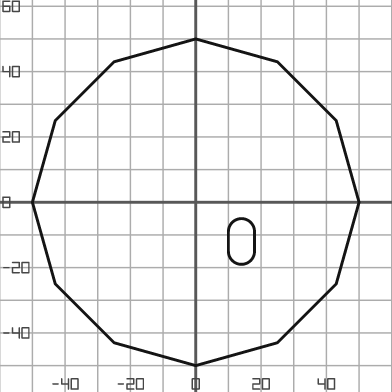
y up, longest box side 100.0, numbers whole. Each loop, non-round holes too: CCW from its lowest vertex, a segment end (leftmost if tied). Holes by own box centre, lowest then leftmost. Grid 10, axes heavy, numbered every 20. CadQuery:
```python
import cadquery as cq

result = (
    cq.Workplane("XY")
    .moveTo(0.0, -50.0)
    .lineTo(25.0, -43.0)
    .lineTo(43.0, -25.0)
    .lineTo(50.0, 0.0)
    .lineTo(43.0, 25.0)
    .lineTo(25.0, 43.0)
    .lineTo(0.0, 50.0)
    .lineTo(-25.0, 43.0)
    .lineTo(-43.0, 25.0)
    .lineTo(-50.0, 0.0)
    .lineTo(-43.0, -25.0)
    .lineTo(-25.0, -43.0)
    .close()
    .moveTo(10.0, -15.0)
    .threePointArc((14.0, -19.0), (18.0, -15.0))
    .lineTo(18.0, -9.0)
    .threePointArc((14.0, -5.0), (10.0, -9.0))
    .close()
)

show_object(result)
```